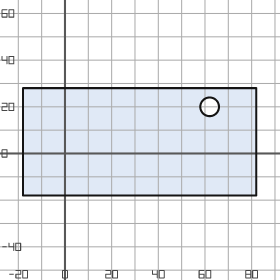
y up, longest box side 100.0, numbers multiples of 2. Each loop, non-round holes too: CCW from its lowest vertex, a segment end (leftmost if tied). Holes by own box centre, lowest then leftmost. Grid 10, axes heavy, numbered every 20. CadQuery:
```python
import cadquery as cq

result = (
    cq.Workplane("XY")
    .moveTo(-18.0, -18.0)
    .lineTo(82.0, -18.0)
    .lineTo(82.0, 28.0)
    .lineTo(-18.0, 28.0)
    .close()
    .moveTo(62.0, 20.0)
    .circle(4.0)
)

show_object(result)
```